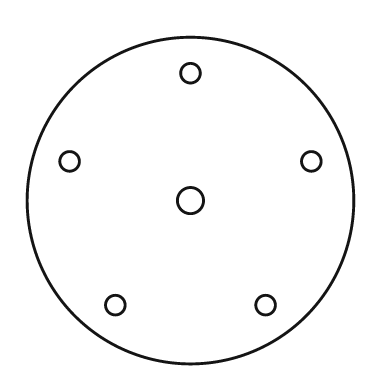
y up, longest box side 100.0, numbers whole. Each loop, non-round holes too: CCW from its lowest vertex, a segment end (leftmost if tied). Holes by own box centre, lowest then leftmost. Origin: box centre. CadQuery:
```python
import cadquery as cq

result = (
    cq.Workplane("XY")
    .moveTo(0.0, 0.0)
    .circle(50.0)
    .moveTo(-23.0, -32.0)
    .circle(3.0)
    .moveTo(23.0, -32.0)
    .circle(3.0)
    .moveTo(0.0, 0.0)
    .circle(4.0)
    .moveTo(-37.0, 12.0)
    .circle(3.0)
    .moveTo(37.0, 12.0)
    .circle(3.0)
    .moveTo(0.0, 39.0)
    .circle(3.0)
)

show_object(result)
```